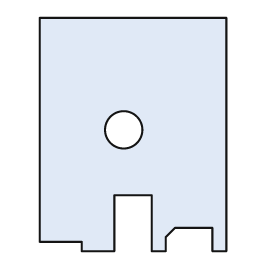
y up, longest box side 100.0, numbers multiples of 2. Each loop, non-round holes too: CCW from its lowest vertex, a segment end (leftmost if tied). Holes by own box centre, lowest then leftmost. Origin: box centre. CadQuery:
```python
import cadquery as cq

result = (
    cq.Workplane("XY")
    .moveTo(-22.0, -50.0)
    .lineTo(-8.0, -50.0)
    .lineTo(-8.0, -26.0)
    .lineTo(8.0, -26.0)
    .lineTo(8.0, -50.0)
    .lineTo(14.0, -50.0)
    .lineTo(14.0, -44.0)
    .lineTo(18.0, -40.0)
    .lineTo(34.0, -40.0)
    .lineTo(34.0, -50.0)
    .lineTo(40.0, -50.0)
    .lineTo(40.0, 50.0)
    .lineTo(-40.0, 50.0)
    .lineTo(-40.0, -46.0)
    .lineTo(-22.0, -46.0)
    .close()
    .moveTo(-4.0, 2.0)
    .circle(8.0)
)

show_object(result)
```